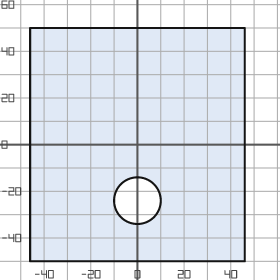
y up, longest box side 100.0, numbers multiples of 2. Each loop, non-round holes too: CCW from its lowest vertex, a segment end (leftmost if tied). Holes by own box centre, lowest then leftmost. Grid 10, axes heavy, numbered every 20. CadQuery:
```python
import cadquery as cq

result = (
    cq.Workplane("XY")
    .moveTo(-46.0, -50.0)
    .lineTo(46.0, -50.0)
    .lineTo(46.0, 50.0)
    .lineTo(-46.0, 50.0)
    .close()
    .moveTo(0.0, -24.0)
    .circle(10.0)
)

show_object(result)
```